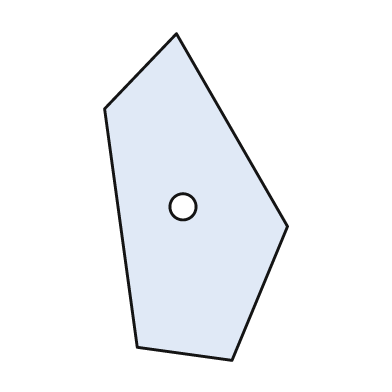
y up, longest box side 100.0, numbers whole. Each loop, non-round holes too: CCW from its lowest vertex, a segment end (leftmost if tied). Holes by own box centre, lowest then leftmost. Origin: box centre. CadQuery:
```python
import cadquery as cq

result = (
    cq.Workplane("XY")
    .moveTo(11.0, -50.0)
    .lineTo(28.0, -9.0)
    .lineTo(-6.0, 50.0)
    .lineTo(-28.0, 27.0)
    .lineTo(-18.0, -46.0)
    .close()
    .moveTo(-4.0, -3.0)
    .circle(4.0)
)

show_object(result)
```